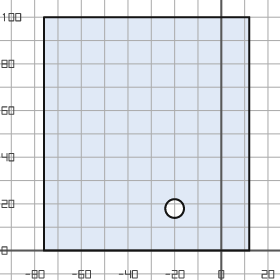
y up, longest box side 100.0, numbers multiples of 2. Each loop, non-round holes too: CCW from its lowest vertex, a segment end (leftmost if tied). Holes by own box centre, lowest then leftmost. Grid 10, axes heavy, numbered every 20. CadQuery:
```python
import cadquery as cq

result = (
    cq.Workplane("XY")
    .moveTo(-76.0, 0.0)
    .lineTo(12.0, 0.0)
    .lineTo(12.0, 100.0)
    .lineTo(-76.0, 100.0)
    .close()
    .moveTo(-20.0, 18.0)
    .circle(4.0)
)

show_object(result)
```